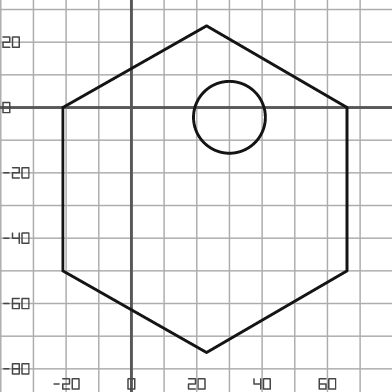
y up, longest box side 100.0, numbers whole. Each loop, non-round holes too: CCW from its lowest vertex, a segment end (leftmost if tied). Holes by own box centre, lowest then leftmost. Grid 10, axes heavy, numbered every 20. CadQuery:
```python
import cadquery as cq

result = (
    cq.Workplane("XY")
    .moveTo(23.0, -75.0)
    .lineTo(66.0, -50.0)
    .lineTo(66.0, 0.0)
    .lineTo(23.0, 25.0)
    .lineTo(-21.0, 0.0)
    .lineTo(-21.0, -50.0)
    .close()
    .moveTo(30.0, -3.0)
    .circle(11.0)
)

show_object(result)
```